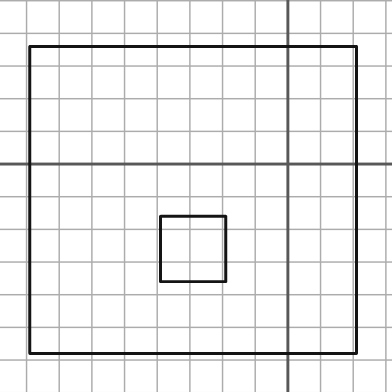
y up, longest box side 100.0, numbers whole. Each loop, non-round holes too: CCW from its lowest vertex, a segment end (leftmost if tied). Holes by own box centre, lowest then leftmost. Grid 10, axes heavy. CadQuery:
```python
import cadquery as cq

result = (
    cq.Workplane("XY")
    .moveTo(-79.0, -58.0)
    .lineTo(21.0, -58.0)
    .lineTo(21.0, 36.0)
    .lineTo(-79.0, 36.0)
    .close()
    .moveTo(-39.0, -36.0)
    .lineTo(-19.0, -36.0)
    .lineTo(-19.0, -16.0)
    .lineTo(-39.0, -16.0)
    .close()
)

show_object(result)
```